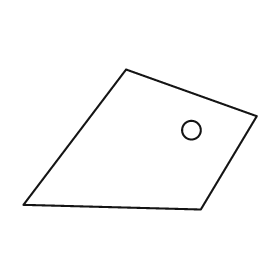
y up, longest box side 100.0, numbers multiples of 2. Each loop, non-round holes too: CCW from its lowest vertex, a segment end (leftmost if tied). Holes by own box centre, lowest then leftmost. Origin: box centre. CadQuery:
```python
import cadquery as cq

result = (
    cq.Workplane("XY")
    .moveTo(26.0, -30.0)
    .lineTo(50.0, 10.0)
    .lineTo(-6.0, 30.0)
    .lineTo(-50.0, -28.0)
    .close()
    .moveTo(22.0, 4.0)
    .circle(4.0)
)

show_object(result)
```